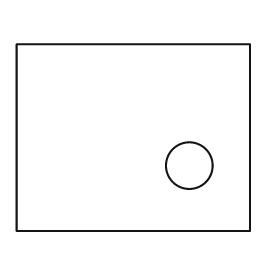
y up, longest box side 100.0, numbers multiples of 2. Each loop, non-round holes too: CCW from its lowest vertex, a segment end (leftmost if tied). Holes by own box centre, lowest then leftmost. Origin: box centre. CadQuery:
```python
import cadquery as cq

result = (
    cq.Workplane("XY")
    .moveTo(-50.0, -40.0)
    .lineTo(50.0, -40.0)
    .lineTo(50.0, 40.0)
    .lineTo(-50.0, 40.0)
    .close()
    .moveTo(24.0, -12.0)
    .circle(10.0)
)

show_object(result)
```